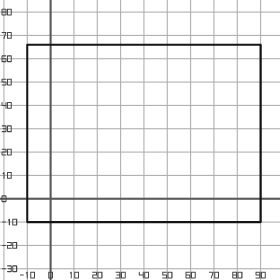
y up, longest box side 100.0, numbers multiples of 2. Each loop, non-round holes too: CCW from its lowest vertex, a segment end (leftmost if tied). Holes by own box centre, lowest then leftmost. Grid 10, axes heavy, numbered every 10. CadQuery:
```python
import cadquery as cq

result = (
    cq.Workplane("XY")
    .moveTo(-10.0, -10.0)
    .lineTo(90.0, -10.0)
    .lineTo(90.0, 66.0)
    .lineTo(-10.0, 66.0)
    .close()
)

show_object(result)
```